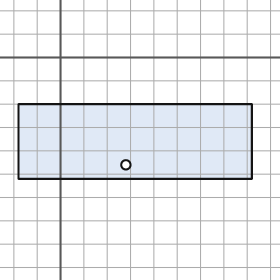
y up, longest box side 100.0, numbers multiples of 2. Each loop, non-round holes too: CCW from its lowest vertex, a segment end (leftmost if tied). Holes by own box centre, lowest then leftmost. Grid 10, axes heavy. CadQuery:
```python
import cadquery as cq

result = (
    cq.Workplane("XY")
    .moveTo(-18.0, -52.0)
    .lineTo(82.0, -52.0)
    .lineTo(82.0, -20.0)
    .lineTo(-18.0, -20.0)
    .close()
    .moveTo(28.0, -46.0)
    .circle(2.0)
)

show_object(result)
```